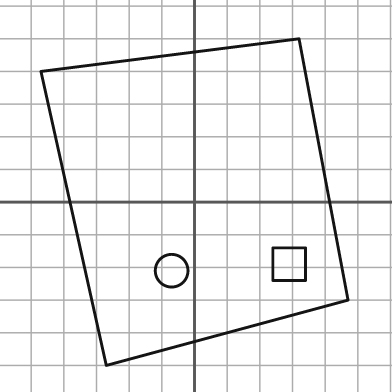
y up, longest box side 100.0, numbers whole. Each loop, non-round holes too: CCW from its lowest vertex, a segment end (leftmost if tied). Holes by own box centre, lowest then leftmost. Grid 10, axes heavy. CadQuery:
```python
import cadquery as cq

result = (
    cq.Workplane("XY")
    .moveTo(-27.0, -50.0)
    .lineTo(47.0, -30.0)
    .lineTo(32.0, 50.0)
    .lineTo(-47.0, 40.0)
    .close()
    .moveTo(-7.0, -21.0)
    .circle(5.0)
    .moveTo(24.0, -24.0)
    .lineTo(34.0, -24.0)
    .lineTo(34.0, -14.0)
    .lineTo(24.0, -14.0)
    .close()
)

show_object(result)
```